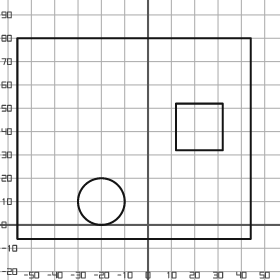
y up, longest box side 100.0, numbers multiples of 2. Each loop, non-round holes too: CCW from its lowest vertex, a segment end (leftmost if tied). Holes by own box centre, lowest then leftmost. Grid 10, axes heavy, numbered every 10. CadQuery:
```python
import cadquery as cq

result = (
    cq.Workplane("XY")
    .moveTo(-56.0, -6.0)
    .lineTo(44.0, -6.0)
    .lineTo(44.0, 80.0)
    .lineTo(-56.0, 80.0)
    .close()
    .moveTo(-20.0, 10.0)
    .circle(10.0)
    .moveTo(12.0, 32.0)
    .lineTo(32.0, 32.0)
    .lineTo(32.0, 52.0)
    .lineTo(12.0, 52.0)
    .close()
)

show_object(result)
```